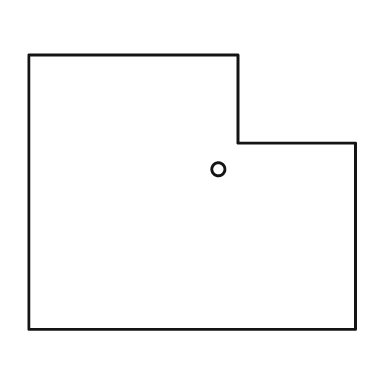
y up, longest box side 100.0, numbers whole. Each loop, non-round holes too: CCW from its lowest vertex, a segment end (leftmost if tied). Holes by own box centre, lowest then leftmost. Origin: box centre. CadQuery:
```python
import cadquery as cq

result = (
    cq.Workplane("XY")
    .moveTo(-50.0, -42.0)
    .lineTo(50.0, -42.0)
    .lineTo(50.0, 15.0)
    .lineTo(14.0, 15.0)
    .lineTo(14.0, 42.0)
    .lineTo(-50.0, 42.0)
    .close()
    .moveTo(8.0, 7.0)
    .circle(2.0)
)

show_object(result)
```